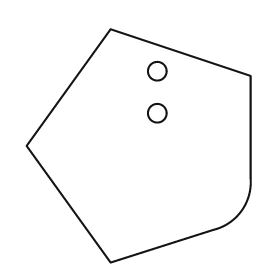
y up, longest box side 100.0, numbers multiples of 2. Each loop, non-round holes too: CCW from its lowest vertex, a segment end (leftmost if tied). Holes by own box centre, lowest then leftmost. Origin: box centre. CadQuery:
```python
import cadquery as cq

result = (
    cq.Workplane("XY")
    .moveTo(-12.0, -50.0)
    .lineTo(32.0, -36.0)
    .threePointArc((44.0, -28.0), (48.0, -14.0))
    .lineTo(48.0, 30.0)
    .lineTo(-12.0, 50.0)
    .lineTo(-48.0, 0.0)
    .close()
    .moveTo(8.0, 14.0)
    .circle(4.0)
    .moveTo(8.0, 32.0)
    .circle(4.0)
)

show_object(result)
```